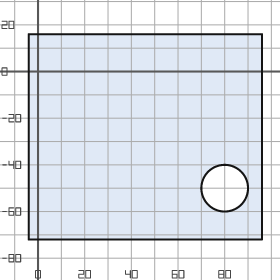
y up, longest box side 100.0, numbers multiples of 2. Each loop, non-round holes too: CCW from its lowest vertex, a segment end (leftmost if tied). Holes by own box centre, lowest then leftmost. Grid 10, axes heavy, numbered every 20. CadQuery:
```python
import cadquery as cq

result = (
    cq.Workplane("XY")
    .moveTo(-4.0, -72.0)
    .lineTo(96.0, -72.0)
    .lineTo(96.0, 16.0)
    .lineTo(-4.0, 16.0)
    .close()
    .moveTo(80.0, -50.0)
    .circle(10.0)
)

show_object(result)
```